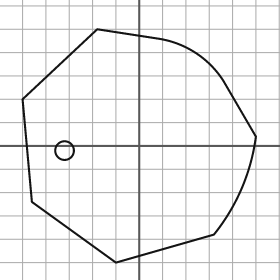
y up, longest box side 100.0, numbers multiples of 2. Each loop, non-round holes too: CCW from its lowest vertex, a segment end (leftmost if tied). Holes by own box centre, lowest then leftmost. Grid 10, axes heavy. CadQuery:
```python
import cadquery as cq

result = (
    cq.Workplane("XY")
    .moveTo(-10.0, -50.0)
    .lineTo(32.0, -38.0)
    .threePointArc((44.0, -18.0), (50.0, 4.0))
    .lineTo(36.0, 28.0)
    .threePointArc((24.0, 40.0), (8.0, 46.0))
    .lineTo(-18.0, 50.0)
    .lineTo(-50.0, 20.0)
    .lineTo(-46.0, -24.0)
    .close()
    .moveTo(-32.0, -2.0)
    .circle(4.0)
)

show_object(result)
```